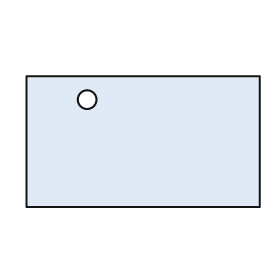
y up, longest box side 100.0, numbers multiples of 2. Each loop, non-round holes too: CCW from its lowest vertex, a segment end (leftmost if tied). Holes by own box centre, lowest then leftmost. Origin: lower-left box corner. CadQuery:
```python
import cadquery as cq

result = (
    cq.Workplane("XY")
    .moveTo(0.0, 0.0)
    .lineTo(100.0, 0.0)
    .lineTo(100.0, 56.0)
    .lineTo(0.0, 56.0)
    .close()
    .moveTo(26.0, 46.0)
    .circle(4.0)
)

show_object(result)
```